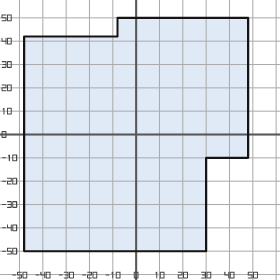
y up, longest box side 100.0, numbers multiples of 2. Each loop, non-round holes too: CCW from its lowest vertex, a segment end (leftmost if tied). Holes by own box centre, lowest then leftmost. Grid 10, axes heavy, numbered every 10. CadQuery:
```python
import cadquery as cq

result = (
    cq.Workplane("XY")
    .moveTo(-48.0, -50.0)
    .lineTo(30.0, -50.0)
    .lineTo(30.0, -10.0)
    .lineTo(48.0, -10.0)
    .lineTo(48.0, 50.0)
    .lineTo(-8.0, 50.0)
    .lineTo(-8.0, 42.0)
    .lineTo(-48.0, 42.0)
    .close()
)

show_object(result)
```